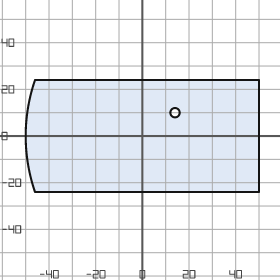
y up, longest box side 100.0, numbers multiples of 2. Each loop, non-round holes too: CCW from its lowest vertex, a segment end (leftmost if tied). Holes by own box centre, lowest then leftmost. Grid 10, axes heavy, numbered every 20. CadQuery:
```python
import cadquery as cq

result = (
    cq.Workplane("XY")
    .moveTo(-46.0, -24.0)
    .lineTo(50.0, -24.0)
    .lineTo(50.0, 24.0)
    .lineTo(-46.0, 24.0)
    .threePointArc((-50.0, 0.0), (-46.0, -24.0))
    .close()
    .moveTo(14.0, 10.0)
    .circle(2.0)
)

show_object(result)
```